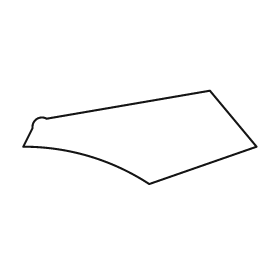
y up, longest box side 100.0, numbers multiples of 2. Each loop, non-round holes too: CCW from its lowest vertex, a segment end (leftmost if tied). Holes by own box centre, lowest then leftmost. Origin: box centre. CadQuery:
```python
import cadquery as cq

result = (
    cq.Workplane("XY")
    .moveTo(4.0, -20.0)
    .lineTo(50.0, -4.0)
    .lineTo(30.0, 20.0)
    .lineTo(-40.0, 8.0)
    .threePointArc((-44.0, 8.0), (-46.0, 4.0))
    .lineTo(-50.0, -4.0)
    .threePointArc((-22.0, -8.0), (4.0, -20.0))
    .close()
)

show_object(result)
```